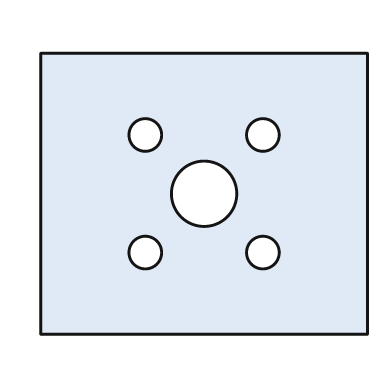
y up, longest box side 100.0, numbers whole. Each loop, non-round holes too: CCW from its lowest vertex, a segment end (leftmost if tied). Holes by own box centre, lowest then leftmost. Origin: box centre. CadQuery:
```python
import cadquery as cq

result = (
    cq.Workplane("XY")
    .moveTo(-50.0, -43.0)
    .lineTo(50.0, -43.0)
    .lineTo(50.0, 43.0)
    .lineTo(-50.0, 43.0)
    .close()
    .moveTo(-18.0, -18.0)
    .circle(5.0)
    .moveTo(18.0, -18.0)
    .circle(5.0)
    .moveTo(0.0, 0.0)
    .circle(10.0)
    .moveTo(-18.0, 18.0)
    .circle(5.0)
    .moveTo(18.0, 18.0)
    .circle(5.0)
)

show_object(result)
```